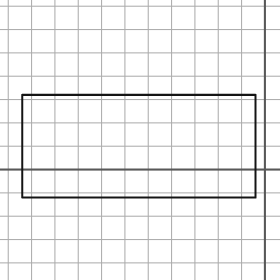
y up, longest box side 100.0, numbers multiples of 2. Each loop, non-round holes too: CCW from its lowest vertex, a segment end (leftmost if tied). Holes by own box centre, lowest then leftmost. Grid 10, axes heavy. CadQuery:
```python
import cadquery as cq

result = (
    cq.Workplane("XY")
    .moveTo(-104.0, -12.0)
    .lineTo(-4.0, -12.0)
    .lineTo(-4.0, 32.0)
    .lineTo(-104.0, 32.0)
    .close()
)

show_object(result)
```